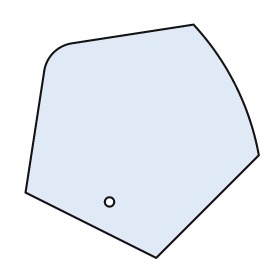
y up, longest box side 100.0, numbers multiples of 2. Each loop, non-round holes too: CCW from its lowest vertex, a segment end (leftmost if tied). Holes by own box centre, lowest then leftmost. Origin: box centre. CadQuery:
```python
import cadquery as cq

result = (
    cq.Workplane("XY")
    .moveTo(6.0, -50.0)
    .lineTo(50.0, -6.0)
    .threePointArc((40.0, 24.0), (22.0, 50.0))
    .lineTo(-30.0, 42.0)
    .threePointArc((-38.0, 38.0), (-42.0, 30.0))
    .lineTo(-50.0, -22.0)
    .close()
    .moveTo(-14.0, -26.0)
    .circle(2.0)
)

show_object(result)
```